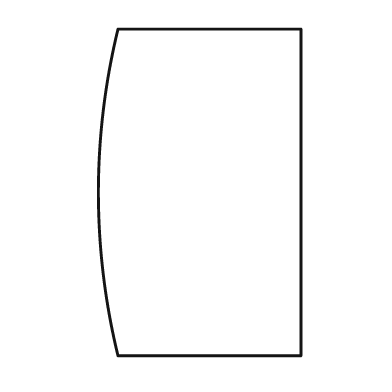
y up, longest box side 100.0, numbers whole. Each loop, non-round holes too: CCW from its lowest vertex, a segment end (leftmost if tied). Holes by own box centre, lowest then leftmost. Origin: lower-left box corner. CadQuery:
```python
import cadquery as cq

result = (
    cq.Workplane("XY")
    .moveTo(6.0, 0.0)
    .lineTo(62.0, 0.0)
    .lineTo(62.0, 100.0)
    .lineTo(6.0, 100.0)
    .threePointArc((0.0, 50.0), (6.0, 0.0))
    .close()
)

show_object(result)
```